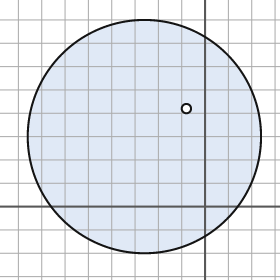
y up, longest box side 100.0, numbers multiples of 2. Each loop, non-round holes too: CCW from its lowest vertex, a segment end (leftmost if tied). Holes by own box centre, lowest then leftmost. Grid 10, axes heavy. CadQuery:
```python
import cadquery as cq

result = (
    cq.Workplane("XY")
    .moveTo(-26.0, 30.0)
    .circle(50.0)
    .moveTo(-8.0, 42.0)
    .circle(2.0)
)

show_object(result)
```